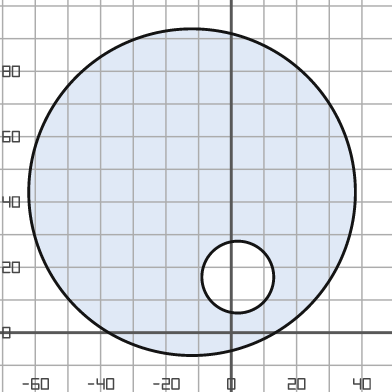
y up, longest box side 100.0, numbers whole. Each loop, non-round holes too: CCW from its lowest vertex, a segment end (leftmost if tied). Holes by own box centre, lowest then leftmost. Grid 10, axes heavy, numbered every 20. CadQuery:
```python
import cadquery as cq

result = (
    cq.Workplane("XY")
    .moveTo(-12.0, 43.0)
    .circle(50.0)
    .moveTo(2.0, 17.0)
    .circle(11.0)
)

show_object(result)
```